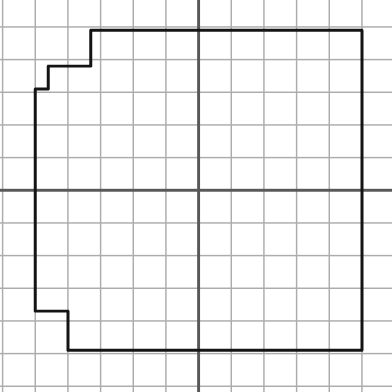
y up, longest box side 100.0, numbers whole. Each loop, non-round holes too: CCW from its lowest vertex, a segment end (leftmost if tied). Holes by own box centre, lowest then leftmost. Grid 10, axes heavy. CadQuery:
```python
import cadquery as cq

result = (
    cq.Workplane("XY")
    .moveTo(-40.0, -49.0)
    .lineTo(50.0, -49.0)
    .lineTo(50.0, 49.0)
    .lineTo(-33.0, 49.0)
    .lineTo(-33.0, 38.0)
    .lineTo(-46.0, 38.0)
    .lineTo(-46.0, 31.0)
    .lineTo(-50.0, 31.0)
    .lineTo(-50.0, -37.0)
    .lineTo(-40.0, -37.0)
    .close()
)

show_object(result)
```